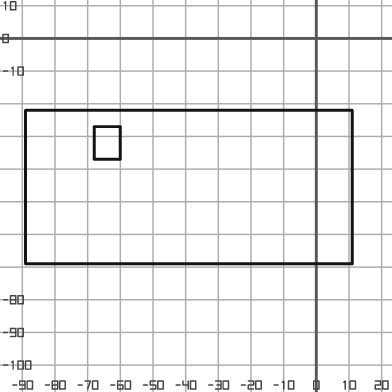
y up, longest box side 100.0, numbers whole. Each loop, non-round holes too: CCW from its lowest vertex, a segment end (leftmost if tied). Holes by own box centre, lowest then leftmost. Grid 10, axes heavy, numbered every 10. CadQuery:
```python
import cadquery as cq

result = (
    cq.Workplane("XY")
    .moveTo(-89.0, -69.0)
    .lineTo(11.0, -69.0)
    .lineTo(11.0, -22.0)
    .lineTo(-89.0, -22.0)
    .close()
    .moveTo(-68.0, -37.0)
    .lineTo(-60.0, -37.0)
    .lineTo(-60.0, -27.0)
    .lineTo(-68.0, -27.0)
    .close()
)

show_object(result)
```